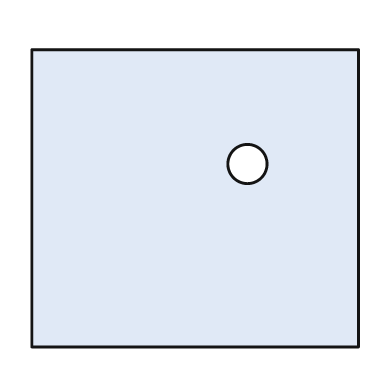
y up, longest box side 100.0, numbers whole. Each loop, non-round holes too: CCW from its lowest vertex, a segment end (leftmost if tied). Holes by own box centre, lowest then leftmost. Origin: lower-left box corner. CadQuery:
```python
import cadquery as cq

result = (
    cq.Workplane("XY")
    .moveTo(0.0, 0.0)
    .lineTo(100.0, 0.0)
    .lineTo(100.0, 91.0)
    .lineTo(0.0, 91.0)
    .close()
    .moveTo(66.0, 56.0)
    .circle(6.0)
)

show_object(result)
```